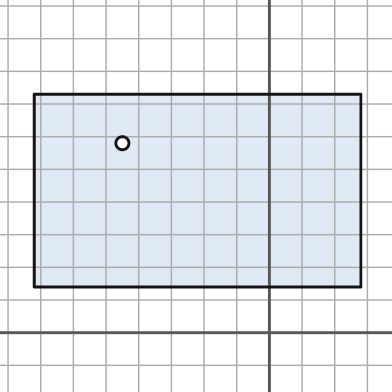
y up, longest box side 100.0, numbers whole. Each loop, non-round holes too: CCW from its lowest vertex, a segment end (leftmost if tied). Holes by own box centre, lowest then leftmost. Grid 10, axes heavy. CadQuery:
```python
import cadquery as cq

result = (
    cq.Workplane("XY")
    .moveTo(-72.0, 14.0)
    .lineTo(28.0, 14.0)
    .lineTo(28.0, 73.0)
    .lineTo(-72.0, 73.0)
    .close()
    .moveTo(-45.0, 58.0)
    .circle(2.0)
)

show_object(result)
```